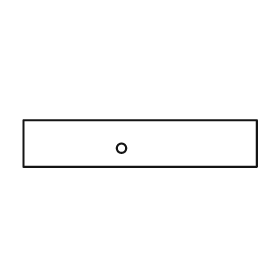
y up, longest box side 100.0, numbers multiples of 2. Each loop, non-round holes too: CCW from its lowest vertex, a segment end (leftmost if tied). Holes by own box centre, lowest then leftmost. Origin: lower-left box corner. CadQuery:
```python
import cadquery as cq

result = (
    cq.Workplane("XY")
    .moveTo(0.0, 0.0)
    .lineTo(100.0, 0.0)
    .lineTo(100.0, 20.0)
    .lineTo(0.0, 20.0)
    .close()
    .moveTo(42.0, 8.0)
    .circle(2.0)
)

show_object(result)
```